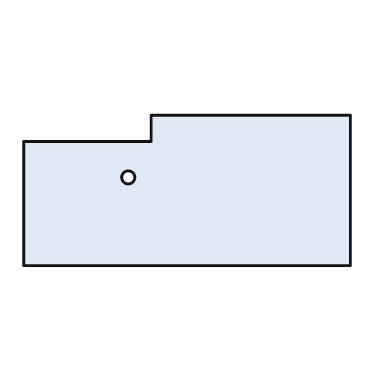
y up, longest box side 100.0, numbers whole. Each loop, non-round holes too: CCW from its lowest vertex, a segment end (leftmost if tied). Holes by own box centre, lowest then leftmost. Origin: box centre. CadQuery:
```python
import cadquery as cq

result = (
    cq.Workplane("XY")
    .moveTo(-50.0, -23.0)
    .lineTo(50.0, -23.0)
    .lineTo(50.0, 23.0)
    .lineTo(-11.0, 23.0)
    .lineTo(-11.0, 15.0)
    .lineTo(-50.0, 15.0)
    .close()
    .moveTo(-18.0, 4.0)
    .circle(2.0)
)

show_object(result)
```